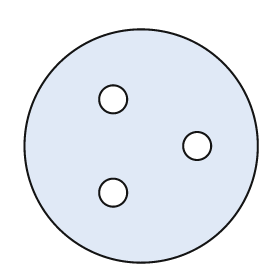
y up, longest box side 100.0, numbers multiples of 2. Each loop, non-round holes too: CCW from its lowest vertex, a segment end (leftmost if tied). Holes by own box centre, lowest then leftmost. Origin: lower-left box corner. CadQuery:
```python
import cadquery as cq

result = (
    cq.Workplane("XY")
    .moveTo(50.0, 50.0)
    .circle(50.0)
    .moveTo(38.0, 30.0)
    .circle(6.0)
    .moveTo(74.0, 50.0)
    .circle(6.0)
    .moveTo(38.0, 70.0)
    .circle(6.0)
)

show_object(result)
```